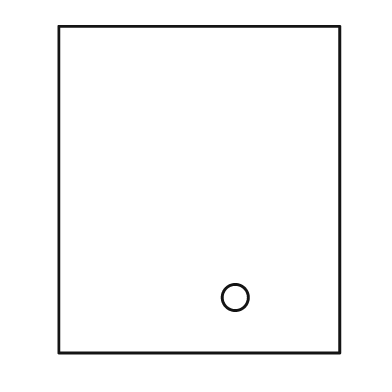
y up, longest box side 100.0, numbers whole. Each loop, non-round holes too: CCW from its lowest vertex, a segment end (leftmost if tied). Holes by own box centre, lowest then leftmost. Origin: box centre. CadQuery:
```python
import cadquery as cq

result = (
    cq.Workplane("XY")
    .moveTo(-43.0, -50.0)
    .lineTo(43.0, -50.0)
    .lineTo(43.0, 50.0)
    .lineTo(-43.0, 50.0)
    .close()
    .moveTo(11.0, -33.0)
    .circle(4.0)
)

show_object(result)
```